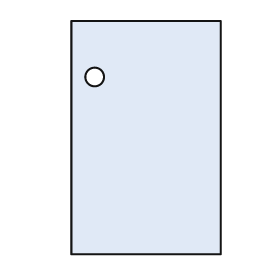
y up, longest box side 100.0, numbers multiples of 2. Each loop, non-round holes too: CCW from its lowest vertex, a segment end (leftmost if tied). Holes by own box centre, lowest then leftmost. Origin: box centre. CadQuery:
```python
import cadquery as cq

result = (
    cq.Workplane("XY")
    .moveTo(-32.0, -50.0)
    .lineTo(32.0, -50.0)
    .lineTo(32.0, 50.0)
    .lineTo(-32.0, 50.0)
    .close()
    .moveTo(-22.0, 26.0)
    .circle(4.0)
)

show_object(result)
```